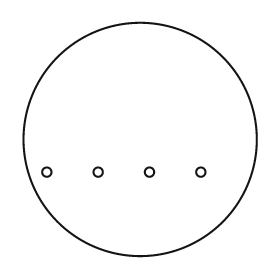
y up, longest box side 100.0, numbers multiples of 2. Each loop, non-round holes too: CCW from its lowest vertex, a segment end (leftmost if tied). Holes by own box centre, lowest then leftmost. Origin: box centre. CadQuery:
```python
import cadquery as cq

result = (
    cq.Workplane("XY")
    .moveTo(0.0, 0.0)
    .circle(50.0)
    .moveTo(-40.0, -14.0)
    .circle(2.0)
    .moveTo(-18.0, -14.0)
    .circle(2.0)
    .moveTo(4.0, -14.0)
    .circle(2.0)
    .moveTo(26.0, -14.0)
    .circle(2.0)
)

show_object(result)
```